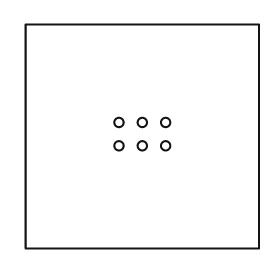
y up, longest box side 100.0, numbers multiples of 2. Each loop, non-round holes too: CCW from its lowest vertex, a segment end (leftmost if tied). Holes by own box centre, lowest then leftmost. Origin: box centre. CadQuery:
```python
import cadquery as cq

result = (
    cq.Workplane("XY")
    .moveTo(-50.0, -48.0)
    .lineTo(50.0, -48.0)
    .lineTo(50.0, 48.0)
    .lineTo(-50.0, 48.0)
    .close()
    .moveTo(-10.0, -4.0)
    .circle(2.0)
    .moveTo(0.0, -4.0)
    .circle(2.0)
    .moveTo(10.0, -4.0)
    .circle(2.0)
    .moveTo(-10.0, 6.0)
    .circle(2.0)
    .moveTo(0.0, 6.0)
    .circle(2.0)
    .moveTo(10.0, 6.0)
    .circle(2.0)
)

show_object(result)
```